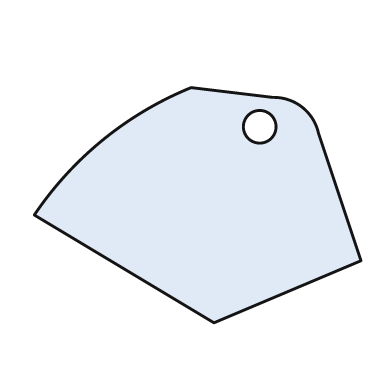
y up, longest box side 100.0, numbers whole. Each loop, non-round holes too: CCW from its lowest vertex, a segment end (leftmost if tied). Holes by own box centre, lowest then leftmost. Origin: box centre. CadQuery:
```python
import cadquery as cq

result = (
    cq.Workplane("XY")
    .moveTo(5.0, -36.0)
    .lineTo(50.0, -17.0)
    .lineTo(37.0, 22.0)
    .threePointArc((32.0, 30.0), (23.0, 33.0))
    .lineTo(-2.0, 36.0)
    .threePointArc((-29.0, 20.0), (-50.0, -3.0))
    .close()
    .moveTo(19.0, 24.0)
    .circle(5.0)
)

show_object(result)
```